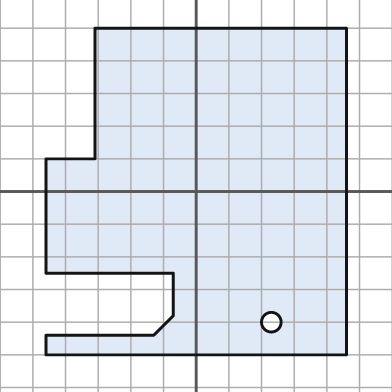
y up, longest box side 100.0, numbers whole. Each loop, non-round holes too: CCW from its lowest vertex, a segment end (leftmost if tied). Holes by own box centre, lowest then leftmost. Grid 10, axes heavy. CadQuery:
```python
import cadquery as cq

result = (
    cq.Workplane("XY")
    .moveTo(-46.0, -50.0)
    .lineTo(46.0, -50.0)
    .lineTo(46.0, 50.0)
    .lineTo(-31.0, 50.0)
    .lineTo(-31.0, 10.0)
    .lineTo(-46.0, 10.0)
    .lineTo(-46.0, -25.0)
    .lineTo(-7.0, -25.0)
    .lineTo(-7.0, -38.0)
    .lineTo(-13.0, -44.0)
    .lineTo(-46.0, -44.0)
    .close()
    .moveTo(23.0, -40.0)
    .circle(3.0)
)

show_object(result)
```